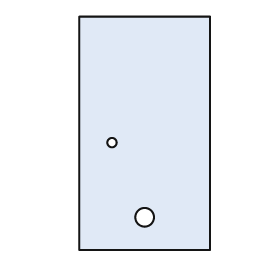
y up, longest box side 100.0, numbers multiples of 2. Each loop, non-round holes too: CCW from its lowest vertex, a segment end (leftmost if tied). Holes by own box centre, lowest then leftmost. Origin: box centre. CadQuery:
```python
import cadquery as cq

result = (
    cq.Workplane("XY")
    .moveTo(-28.0, -50.0)
    .lineTo(28.0, -50.0)
    .lineTo(28.0, 50.0)
    .lineTo(-28.0, 50.0)
    .close()
    .moveTo(0.0, -36.0)
    .circle(4.0)
    .moveTo(-14.0, -4.0)
    .circle(2.0)
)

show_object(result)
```